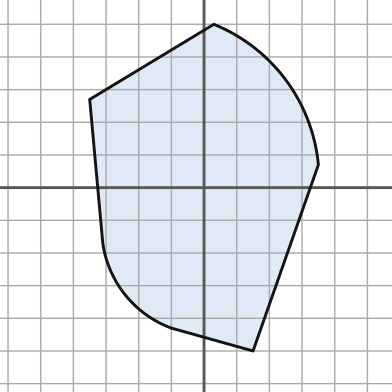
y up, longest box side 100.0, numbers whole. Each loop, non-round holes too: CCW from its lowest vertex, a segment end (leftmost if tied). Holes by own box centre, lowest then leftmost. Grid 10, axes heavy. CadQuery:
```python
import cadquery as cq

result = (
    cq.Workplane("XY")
    .moveTo(15.0, -50.0)
    .lineTo(35.0, 7.0)
    .threePointArc((25.0, 33.0), (3.0, 50.0))
    .lineTo(-35.0, 27.0)
    .lineTo(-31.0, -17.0)
    .threePointArc((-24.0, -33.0), (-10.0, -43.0))
    .close()
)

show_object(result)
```